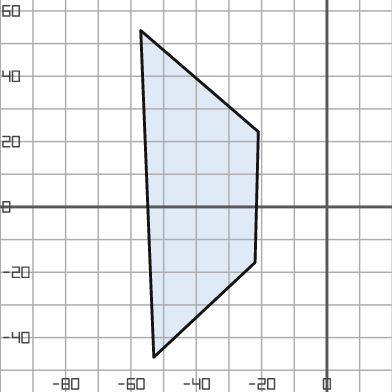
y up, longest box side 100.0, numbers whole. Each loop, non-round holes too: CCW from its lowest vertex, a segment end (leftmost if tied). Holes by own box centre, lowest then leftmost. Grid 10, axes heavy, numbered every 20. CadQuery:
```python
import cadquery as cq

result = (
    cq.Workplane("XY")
    .moveTo(-53.0, -46.0)
    .lineTo(-22.0, -17.0)
    .lineTo(-21.0, 23.0)
    .lineTo(-57.0, 54.0)
    .close()
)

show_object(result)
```